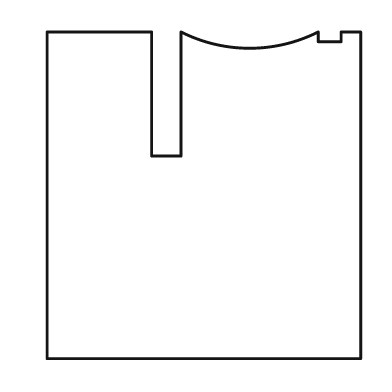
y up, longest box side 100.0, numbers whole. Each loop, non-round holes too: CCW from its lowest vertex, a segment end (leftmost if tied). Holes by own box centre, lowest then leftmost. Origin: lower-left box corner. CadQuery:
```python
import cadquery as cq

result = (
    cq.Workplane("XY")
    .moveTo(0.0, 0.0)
    .lineTo(96.0, 0.0)
    .lineTo(96.0, 100.0)
    .lineTo(90.0, 100.0)
    .lineTo(90.0, 97.0)
    .lineTo(83.0, 97.0)
    .lineTo(83.0, 100.0)
    .threePointArc((62.0, 95.0), (41.0, 100.0))
    .lineTo(41.0, 62.0)
    .lineTo(32.0, 62.0)
    .lineTo(32.0, 100.0)
    .lineTo(0.0, 100.0)
    .close()
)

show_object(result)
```